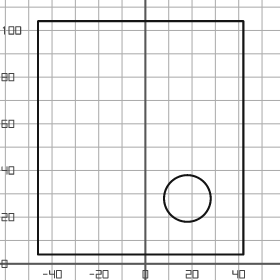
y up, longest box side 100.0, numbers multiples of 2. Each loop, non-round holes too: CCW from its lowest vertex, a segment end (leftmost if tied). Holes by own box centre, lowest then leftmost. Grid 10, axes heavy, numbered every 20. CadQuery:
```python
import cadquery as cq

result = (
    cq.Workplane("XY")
    .moveTo(-46.0, 4.0)
    .lineTo(42.0, 4.0)
    .lineTo(42.0, 104.0)
    .lineTo(-46.0, 104.0)
    .close()
    .moveTo(18.0, 28.0)
    .circle(10.0)
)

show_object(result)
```